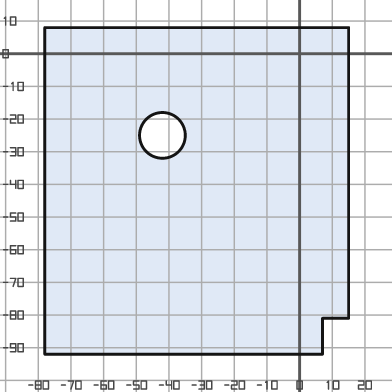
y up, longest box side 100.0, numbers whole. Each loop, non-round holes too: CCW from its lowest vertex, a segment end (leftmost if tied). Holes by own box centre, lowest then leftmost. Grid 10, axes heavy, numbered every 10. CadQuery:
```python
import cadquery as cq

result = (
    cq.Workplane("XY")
    .moveTo(-78.0, -92.0)
    .lineTo(7.0, -92.0)
    .lineTo(7.0, -81.0)
    .lineTo(15.0, -81.0)
    .lineTo(15.0, 8.0)
    .lineTo(-78.0, 8.0)
    .close()
    .moveTo(-42.0, -25.0)
    .circle(7.0)
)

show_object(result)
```